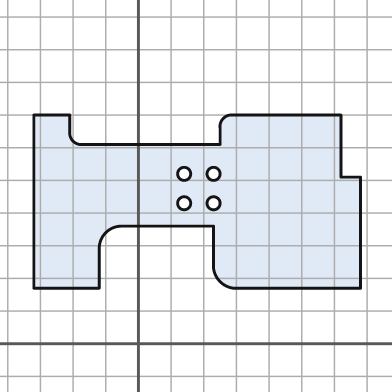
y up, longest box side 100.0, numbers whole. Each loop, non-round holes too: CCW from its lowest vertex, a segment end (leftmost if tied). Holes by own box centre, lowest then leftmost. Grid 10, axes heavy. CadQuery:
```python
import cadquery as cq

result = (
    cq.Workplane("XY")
    .moveTo(-32.0, 17.0)
    .lineTo(-12.0, 17.0)
    .lineTo(-12.0, 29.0)
    .threePointArc((-10.0, 34.0), (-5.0, 36.0))
    .lineTo(23.0, 36.0)
    .lineTo(23.0, 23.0)
    .threePointArc((25.0, 19.0), (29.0, 17.0))
    .lineTo(68.0, 17.0)
    .lineTo(68.0, 51.0)
    .lineTo(62.0, 51.0)
    .lineTo(62.0, 70.0)
    .lineTo(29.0, 70.0)
    .threePointArc((26.0, 69.0), (25.0, 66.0))
    .lineTo(25.0, 61.0)
    .lineTo(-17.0, 61.0)
    .threePointArc((-20.0, 62.0), (-21.0, 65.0))
    .lineTo(-21.0, 70.0)
    .lineTo(-32.0, 70.0)
    .close()
    .moveTo(14.0, 43.0)
    .circle(2.0)
    .moveTo(23.0, 43.0)
    .circle(2.0)
    .moveTo(14.0, 52.0)
    .circle(2.0)
    .moveTo(23.0, 52.0)
    .circle(2.0)
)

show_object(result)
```